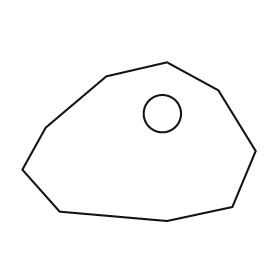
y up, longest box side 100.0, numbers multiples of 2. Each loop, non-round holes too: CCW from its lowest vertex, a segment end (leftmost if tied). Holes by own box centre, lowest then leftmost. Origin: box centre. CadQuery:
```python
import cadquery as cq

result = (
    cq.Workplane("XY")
    .moveTo(12.0, -34.0)
    .lineTo(40.0, -28.0)
    .lineTo(50.0, -4.0)
    .lineTo(34.0, 22.0)
    .lineTo(12.0, 34.0)
    .lineTo(-14.0, 28.0)
    .lineTo(-40.0, 6.0)
    .lineTo(-50.0, -12.0)
    .lineTo(-34.0, -30.0)
    .close()
    .moveTo(10.0, 12.0)
    .circle(8.0)
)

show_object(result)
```